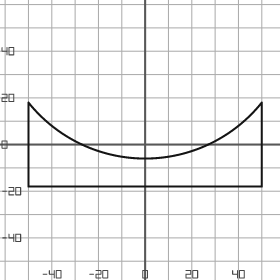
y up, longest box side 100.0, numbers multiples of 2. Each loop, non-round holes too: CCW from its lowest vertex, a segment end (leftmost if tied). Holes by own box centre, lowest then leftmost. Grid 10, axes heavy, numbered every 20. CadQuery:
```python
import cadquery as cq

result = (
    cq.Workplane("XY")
    .moveTo(-50.0, -18.0)
    .lineTo(50.0, -18.0)
    .lineTo(50.0, 18.0)
    .threePointArc((0.0, -6.0), (-50.0, 18.0))
    .close()
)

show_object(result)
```